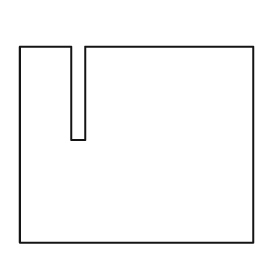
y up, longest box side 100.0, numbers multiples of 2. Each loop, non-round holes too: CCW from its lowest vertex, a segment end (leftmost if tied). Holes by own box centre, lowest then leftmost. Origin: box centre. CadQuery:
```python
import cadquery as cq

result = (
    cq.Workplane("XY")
    .moveTo(-50.0, -42.0)
    .lineTo(50.0, -42.0)
    .lineTo(50.0, 42.0)
    .lineTo(-22.0, 42.0)
    .lineTo(-22.0, 2.0)
    .lineTo(-28.0, 2.0)
    .lineTo(-28.0, 42.0)
    .lineTo(-50.0, 42.0)
    .close()
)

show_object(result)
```